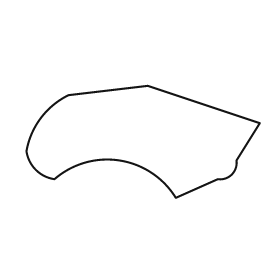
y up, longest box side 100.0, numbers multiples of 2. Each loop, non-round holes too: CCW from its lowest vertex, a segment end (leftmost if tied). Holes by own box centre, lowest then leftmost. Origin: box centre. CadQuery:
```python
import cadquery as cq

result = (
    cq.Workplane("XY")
    .moveTo(14.0, -24.0)
    .lineTo(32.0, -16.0)
    .threePointArc((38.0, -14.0), (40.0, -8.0))
    .lineTo(50.0, 8.0)
    .lineTo(2.0, 24.0)
    .lineTo(-32.0, 20.0)
    .threePointArc((-44.0, 10.0), (-50.0, -4.0))
    .threePointArc((-46.0, -12.0), (-38.0, -16.0))
    .threePointArc((-10.0, -8.0), (14.0, -24.0))
    .close()
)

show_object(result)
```